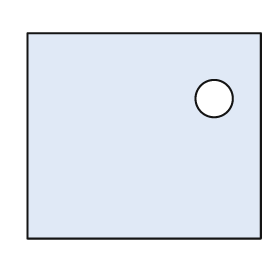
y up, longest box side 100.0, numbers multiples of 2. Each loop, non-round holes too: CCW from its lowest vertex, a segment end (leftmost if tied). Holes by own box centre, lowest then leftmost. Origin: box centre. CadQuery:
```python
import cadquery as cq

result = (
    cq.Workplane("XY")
    .moveTo(-50.0, -44.0)
    .lineTo(50.0, -44.0)
    .lineTo(50.0, 44.0)
    .lineTo(-50.0, 44.0)
    .close()
    .moveTo(30.0, 16.0)
    .circle(8.0)
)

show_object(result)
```